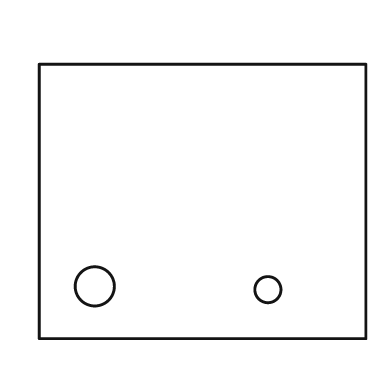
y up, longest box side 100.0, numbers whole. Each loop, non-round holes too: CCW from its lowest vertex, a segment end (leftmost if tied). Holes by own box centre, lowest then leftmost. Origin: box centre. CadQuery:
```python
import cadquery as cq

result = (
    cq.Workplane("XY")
    .moveTo(-50.0, -42.0)
    .lineTo(50.0, -42.0)
    .lineTo(50.0, 42.0)
    .lineTo(-50.0, 42.0)
    .close()
    .moveTo(20.0, -27.0)
    .circle(4.0)
    .moveTo(-33.0, -26.0)
    .circle(6.0)
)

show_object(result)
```